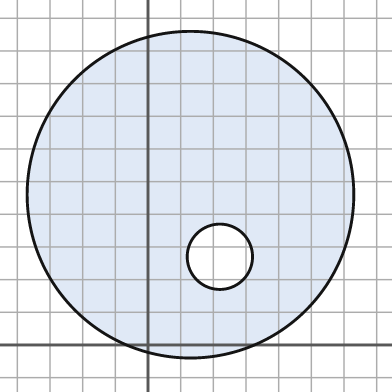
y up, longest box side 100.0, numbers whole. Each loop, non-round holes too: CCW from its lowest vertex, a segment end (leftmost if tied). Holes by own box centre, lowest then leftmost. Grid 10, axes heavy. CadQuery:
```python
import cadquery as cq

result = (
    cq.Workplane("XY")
    .moveTo(13.0, 46.0)
    .circle(50.0)
    .moveTo(22.0, 27.0)
    .circle(10.0)
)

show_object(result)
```